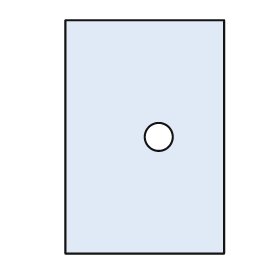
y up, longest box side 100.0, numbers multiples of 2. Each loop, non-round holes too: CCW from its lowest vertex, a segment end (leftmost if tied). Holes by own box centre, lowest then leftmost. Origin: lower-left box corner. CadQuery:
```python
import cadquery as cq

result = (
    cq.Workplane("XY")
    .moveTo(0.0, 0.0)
    .lineTo(68.0, 0.0)
    .lineTo(68.0, 100.0)
    .lineTo(0.0, 100.0)
    .close()
    .moveTo(40.0, 50.0)
    .circle(6.0)
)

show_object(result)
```